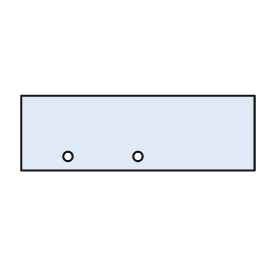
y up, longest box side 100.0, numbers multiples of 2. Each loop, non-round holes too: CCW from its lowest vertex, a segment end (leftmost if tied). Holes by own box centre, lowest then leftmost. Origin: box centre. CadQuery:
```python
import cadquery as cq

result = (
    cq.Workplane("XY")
    .moveTo(-50.0, -16.0)
    .lineTo(50.0, -16.0)
    .lineTo(50.0, 16.0)
    .lineTo(-50.0, 16.0)
    .close()
    .moveTo(-30.0, -10.0)
    .circle(2.0)
    .moveTo(0.0, -10.0)
    .circle(2.0)
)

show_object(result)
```